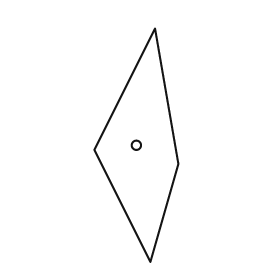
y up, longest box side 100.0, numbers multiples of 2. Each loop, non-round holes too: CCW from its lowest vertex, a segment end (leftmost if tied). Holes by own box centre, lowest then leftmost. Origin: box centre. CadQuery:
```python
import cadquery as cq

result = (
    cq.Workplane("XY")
    .moveTo(6.0, -50.0)
    .lineTo(18.0, -8.0)
    .lineTo(8.0, 50.0)
    .lineTo(-18.0, -2.0)
    .close()
    .moveTo(0.0, 0.0)
    .circle(2.0)
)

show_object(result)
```